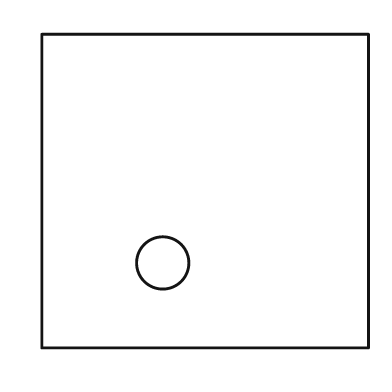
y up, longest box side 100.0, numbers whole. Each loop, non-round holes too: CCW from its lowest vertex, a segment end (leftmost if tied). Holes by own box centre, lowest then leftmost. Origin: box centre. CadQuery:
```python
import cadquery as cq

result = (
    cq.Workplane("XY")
    .moveTo(-50.0, -48.0)
    .lineTo(50.0, -48.0)
    .lineTo(50.0, 48.0)
    .lineTo(-50.0, 48.0)
    .close()
    .moveTo(-13.0, -22.0)
    .circle(8.0)
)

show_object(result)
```